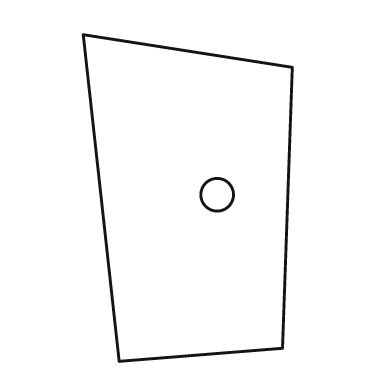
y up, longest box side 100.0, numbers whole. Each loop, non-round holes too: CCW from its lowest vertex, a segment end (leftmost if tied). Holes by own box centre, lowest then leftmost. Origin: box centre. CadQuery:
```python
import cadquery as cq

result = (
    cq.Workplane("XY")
    .moveTo(-21.0, -50.0)
    .lineTo(29.0, -46.0)
    .lineTo(32.0, 40.0)
    .lineTo(-32.0, 50.0)
    .close()
    .moveTo(9.0, 1.0)
    .circle(5.0)
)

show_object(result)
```